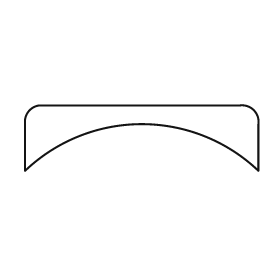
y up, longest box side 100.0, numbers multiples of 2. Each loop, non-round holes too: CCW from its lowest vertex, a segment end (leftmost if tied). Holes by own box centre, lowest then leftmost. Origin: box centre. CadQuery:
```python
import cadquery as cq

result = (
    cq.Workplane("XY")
    .moveTo(-50.0, -14.0)
    .threePointArc((0.0, 6.0), (50.0, -14.0))
    .lineTo(50.0, 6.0)
    .threePointArc((48.0, 12.0), (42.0, 14.0))
    .lineTo(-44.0, 14.0)
    .threePointArc((-48.0, 12.0), (-50.0, 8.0))
    .close()
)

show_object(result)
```